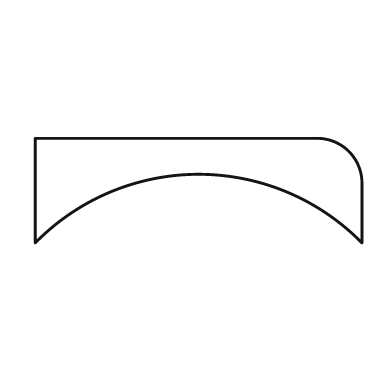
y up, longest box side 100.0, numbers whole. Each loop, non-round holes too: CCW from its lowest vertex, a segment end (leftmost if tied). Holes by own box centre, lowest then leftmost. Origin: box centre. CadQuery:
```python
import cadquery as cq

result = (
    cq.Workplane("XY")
    .moveTo(-50.0, -16.0)
    .threePointArc((0.0, 5.0), (50.0, -16.0))
    .lineTo(50.0, 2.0)
    .threePointArc((46.0, 12.0), (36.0, 16.0))
    .lineTo(-50.0, 16.0)
    .close()
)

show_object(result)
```